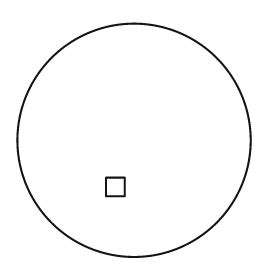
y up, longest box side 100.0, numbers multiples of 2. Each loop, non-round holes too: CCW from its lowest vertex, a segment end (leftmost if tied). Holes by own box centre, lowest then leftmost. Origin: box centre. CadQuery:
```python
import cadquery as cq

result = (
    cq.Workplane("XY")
    .moveTo(0.0, 0.0)
    .circle(50.0)
    .moveTo(-12.0, -24.0)
    .lineTo(-4.0, -24.0)
    .lineTo(-4.0, -16.0)
    .lineTo(-12.0, -16.0)
    .close()
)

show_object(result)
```